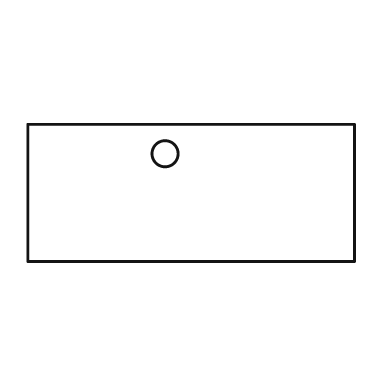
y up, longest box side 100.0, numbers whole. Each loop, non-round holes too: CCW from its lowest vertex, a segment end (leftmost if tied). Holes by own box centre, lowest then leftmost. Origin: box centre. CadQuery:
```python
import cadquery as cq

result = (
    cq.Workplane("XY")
    .moveTo(-50.0, -21.0)
    .lineTo(50.0, -21.0)
    .lineTo(50.0, 21.0)
    .lineTo(-50.0, 21.0)
    .close()
    .moveTo(-8.0, 12.0)
    .circle(4.0)
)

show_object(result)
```